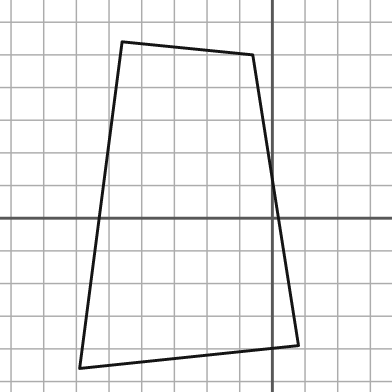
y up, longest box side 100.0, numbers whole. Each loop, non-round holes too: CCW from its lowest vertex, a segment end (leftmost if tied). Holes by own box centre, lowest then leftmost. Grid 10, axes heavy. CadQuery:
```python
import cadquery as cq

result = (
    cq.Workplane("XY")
    .moveTo(-59.0, -46.0)
    .lineTo(8.0, -39.0)
    .lineTo(-6.0, 50.0)
    .lineTo(-46.0, 54.0)
    .close()
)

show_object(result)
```